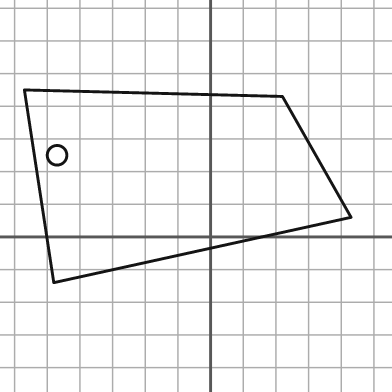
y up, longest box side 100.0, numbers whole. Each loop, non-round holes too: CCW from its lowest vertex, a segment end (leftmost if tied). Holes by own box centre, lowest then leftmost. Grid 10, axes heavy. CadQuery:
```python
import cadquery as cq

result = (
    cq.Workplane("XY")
    .moveTo(-48.0, -14.0)
    .lineTo(43.0, 6.0)
    .lineTo(22.0, 43.0)
    .lineTo(-57.0, 45.0)
    .close()
    .moveTo(-47.0, 25.0)
    .circle(3.0)
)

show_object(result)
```